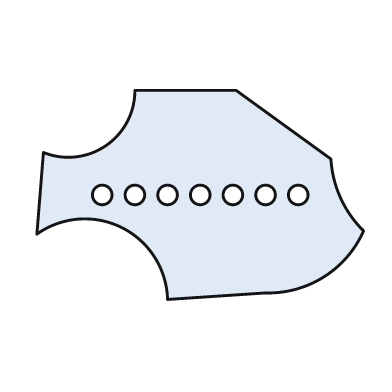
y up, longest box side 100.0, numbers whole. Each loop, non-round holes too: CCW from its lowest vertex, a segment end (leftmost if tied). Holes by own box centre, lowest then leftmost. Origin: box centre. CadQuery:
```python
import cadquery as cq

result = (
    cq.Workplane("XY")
    .moveTo(-10.0, -32.0)
    .lineTo(20.0, -30.0)
    .threePointArc((38.0, -25.0), (50.0, -11.0))
    .threePointArc((43.0, -1.0), (40.0, 11.0))
    .lineTo(11.0, 32.0)
    .lineTo(-20.0, 32.0)
    .threePointArc((-29.0, 15.0), (-48.0, 13.0))
    .lineTo(-50.0, -12.0)
    .threePointArc((-24.0, -10.0), (-10.0, -32.0))
    .close()
    .moveTo(-30.0, 0.0)
    .circle(3.0)
    .moveTo(-20.0, 0.0)
    .circle(3.0)
    .moveTo(-10.0, 0.0)
    .circle(3.0)
    .moveTo(0.0, 0.0)
    .circle(3.0)
    .moveTo(10.0, 0.0)
    .circle(3.0)
    .moveTo(20.0, 0.0)
    .circle(3.0)
    .moveTo(30.0, 0.0)
    .circle(3.0)
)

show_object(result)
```